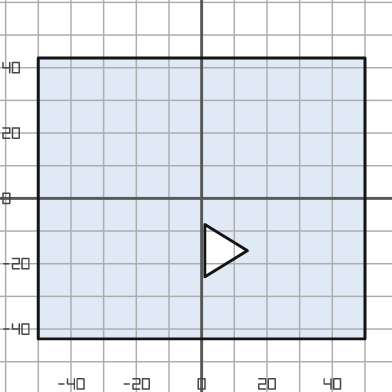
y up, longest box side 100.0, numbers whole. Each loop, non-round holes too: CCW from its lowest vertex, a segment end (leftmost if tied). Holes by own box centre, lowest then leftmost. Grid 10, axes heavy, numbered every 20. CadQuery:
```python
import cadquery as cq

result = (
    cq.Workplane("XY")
    .moveTo(-50.0, -43.0)
    .lineTo(50.0, -43.0)
    .lineTo(50.0, 43.0)
    .lineTo(-50.0, 43.0)
    .close()
    .moveTo(1.0, -24.0)
    .lineTo(14.0, -16.0)
    .lineTo(1.0, -8.0)
    .close()
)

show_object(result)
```